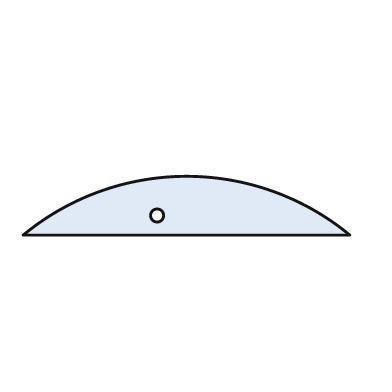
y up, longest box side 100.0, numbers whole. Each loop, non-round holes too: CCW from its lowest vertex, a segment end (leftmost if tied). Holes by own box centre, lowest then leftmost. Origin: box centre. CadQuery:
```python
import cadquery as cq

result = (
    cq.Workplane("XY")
    .moveTo(-50.0, -9.0)
    .lineTo(50.0, -9.0)
    .threePointArc((0.0, 9.0), (-50.0, -9.0))
    .close()
    .moveTo(-9.0, -3.0)
    .circle(2.0)
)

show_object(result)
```